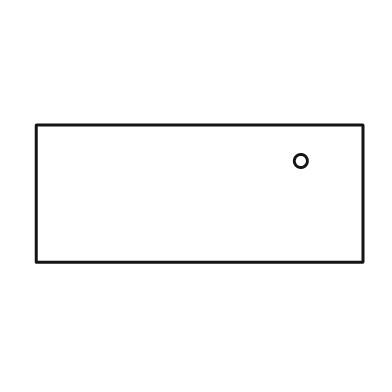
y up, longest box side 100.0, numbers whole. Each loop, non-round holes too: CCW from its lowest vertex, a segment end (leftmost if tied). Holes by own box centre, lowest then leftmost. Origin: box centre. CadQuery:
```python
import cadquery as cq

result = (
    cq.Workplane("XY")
    .moveTo(-50.0, -21.0)
    .lineTo(50.0, -21.0)
    .lineTo(50.0, 21.0)
    .lineTo(-50.0, 21.0)
    .close()
    .moveTo(31.0, 10.0)
    .circle(2.0)
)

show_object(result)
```